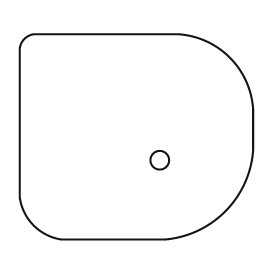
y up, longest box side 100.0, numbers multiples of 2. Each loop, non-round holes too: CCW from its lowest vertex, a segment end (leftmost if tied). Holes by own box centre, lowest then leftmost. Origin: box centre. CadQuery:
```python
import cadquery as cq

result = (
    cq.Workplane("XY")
    .moveTo(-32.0, -44.0)
    .lineTo(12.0, -44.0)
    .threePointArc((38.0, -32.0), (50.0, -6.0))
    .lineTo(50.0, 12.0)
    .threePointArc((40.0, 34.0), (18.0, 44.0))
    .lineTo(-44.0, 44.0)
    .threePointArc((-48.0, 42.0), (-50.0, 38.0))
    .lineTo(-50.0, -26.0)
    .threePointArc((-44.0, -38.0), (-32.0, -44.0))
    .close()
    .moveTo(10.0, -10.0)
    .circle(4.0)
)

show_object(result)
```